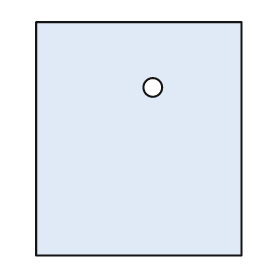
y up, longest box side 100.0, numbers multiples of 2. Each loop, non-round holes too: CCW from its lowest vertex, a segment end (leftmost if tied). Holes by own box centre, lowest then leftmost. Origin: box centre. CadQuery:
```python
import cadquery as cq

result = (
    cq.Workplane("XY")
    .moveTo(-44.0, -50.0)
    .lineTo(44.0, -50.0)
    .lineTo(44.0, 50.0)
    .lineTo(-44.0, 50.0)
    .close()
    .moveTo(6.0, 22.0)
    .circle(4.0)
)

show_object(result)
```